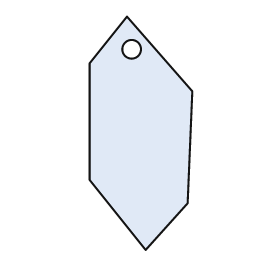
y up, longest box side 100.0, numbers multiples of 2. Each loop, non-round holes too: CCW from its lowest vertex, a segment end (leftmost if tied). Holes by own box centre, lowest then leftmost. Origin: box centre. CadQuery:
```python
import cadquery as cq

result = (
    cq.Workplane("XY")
    .moveTo(2.0, -50.0)
    .lineTo(20.0, -30.0)
    .lineTo(22.0, 18.0)
    .lineTo(-6.0, 50.0)
    .lineTo(-22.0, 30.0)
    .lineTo(-22.0, -20.0)
    .close()
    .moveTo(-4.0, 36.0)
    .circle(4.0)
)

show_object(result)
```